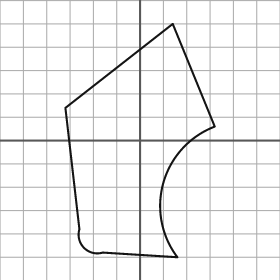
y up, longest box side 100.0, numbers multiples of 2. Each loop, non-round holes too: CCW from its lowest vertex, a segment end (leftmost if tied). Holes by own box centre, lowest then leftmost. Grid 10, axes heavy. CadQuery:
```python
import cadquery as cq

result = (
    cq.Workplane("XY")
    .moveTo(16.0, -50.0)
    .threePointArc((10.0, -18.0), (32.0, 6.0))
    .lineTo(14.0, 50.0)
    .lineTo(-32.0, 14.0)
    .lineTo(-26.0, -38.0)
    .threePointArc((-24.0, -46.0), (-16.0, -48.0))
    .close()
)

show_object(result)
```